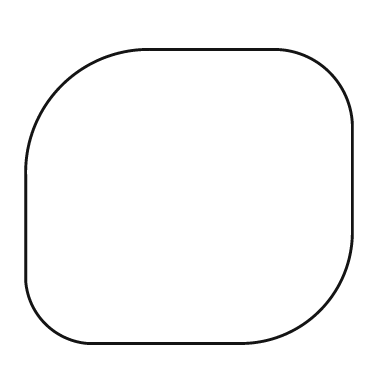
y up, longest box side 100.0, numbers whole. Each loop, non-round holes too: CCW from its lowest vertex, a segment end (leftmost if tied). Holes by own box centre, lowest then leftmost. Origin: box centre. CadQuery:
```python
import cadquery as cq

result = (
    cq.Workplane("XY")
    .moveTo(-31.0, -45.0)
    .lineTo(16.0, -45.0)
    .threePointArc((40.0, -35.0), (50.0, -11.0))
    .lineTo(50.0, 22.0)
    .threePointArc((43.0, 38.0), (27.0, 45.0))
    .lineTo(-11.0, 45.0)
    .threePointArc((-39.0, 34.0), (-50.0, 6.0))
    .lineTo(-50.0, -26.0)
    .threePointArc((-44.0, -39.0), (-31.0, -45.0))
    .close()
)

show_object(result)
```